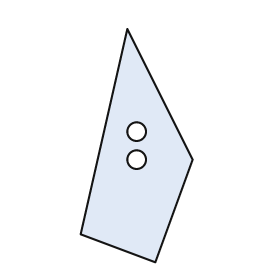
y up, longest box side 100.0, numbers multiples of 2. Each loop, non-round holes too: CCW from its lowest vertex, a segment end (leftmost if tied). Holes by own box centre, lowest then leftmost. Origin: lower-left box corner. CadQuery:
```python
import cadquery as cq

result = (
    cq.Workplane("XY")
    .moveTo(32.0, 0.0)
    .lineTo(48.0, 44.0)
    .lineTo(20.0, 100.0)
    .lineTo(0.0, 12.0)
    .close()
    .moveTo(24.0, 44.0)
    .circle(4.0)
    .moveTo(24.0, 56.0)
    .circle(4.0)
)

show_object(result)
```